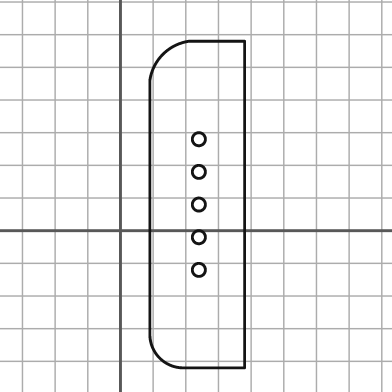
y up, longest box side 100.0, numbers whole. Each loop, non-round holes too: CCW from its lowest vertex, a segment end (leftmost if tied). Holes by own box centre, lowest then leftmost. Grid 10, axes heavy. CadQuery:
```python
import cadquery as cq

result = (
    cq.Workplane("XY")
    .moveTo(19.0, -42.0)
    .lineTo(38.0, -42.0)
    .lineTo(38.0, 58.0)
    .lineTo(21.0, 58.0)
    .threePointArc((13.0, 54.0), (9.0, 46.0))
    .lineTo(9.0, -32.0)
    .threePointArc((12.0, -39.0), (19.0, -42.0))
    .close()
    .moveTo(24.0, -12.0)
    .circle(2.0)
    .moveTo(24.0, -2.0)
    .circle(2.0)
    .moveTo(24.0, 8.0)
    .circle(2.0)
    .moveTo(24.0, 18.0)
    .circle(2.0)
    .moveTo(24.0, 28.0)
    .circle(2.0)
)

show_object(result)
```